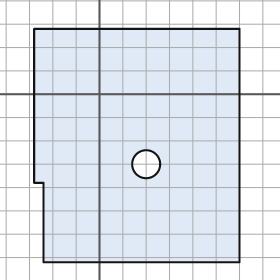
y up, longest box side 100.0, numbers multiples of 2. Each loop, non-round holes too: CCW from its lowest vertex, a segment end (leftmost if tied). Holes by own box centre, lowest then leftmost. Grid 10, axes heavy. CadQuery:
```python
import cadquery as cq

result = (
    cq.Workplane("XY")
    .moveTo(-24.0, -72.0)
    .lineTo(60.0, -72.0)
    .lineTo(60.0, 28.0)
    .lineTo(-28.0, 28.0)
    .lineTo(-28.0, -38.0)
    .lineTo(-24.0, -38.0)
    .close()
    .moveTo(20.0, -30.0)
    .circle(6.0)
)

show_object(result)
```